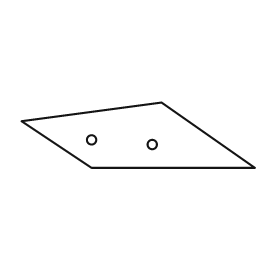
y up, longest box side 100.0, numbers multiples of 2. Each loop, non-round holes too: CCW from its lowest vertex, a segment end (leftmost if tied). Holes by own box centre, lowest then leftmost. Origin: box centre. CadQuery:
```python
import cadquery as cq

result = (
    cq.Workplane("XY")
    .moveTo(-20.0, -14.0)
    .lineTo(50.0, -14.0)
    .lineTo(10.0, 14.0)
    .lineTo(-50.0, 6.0)
    .close()
    .moveTo(6.0, -4.0)
    .circle(2.0)
    .moveTo(-20.0, -2.0)
    .circle(2.0)
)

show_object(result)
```